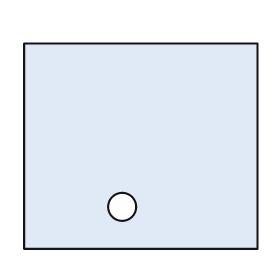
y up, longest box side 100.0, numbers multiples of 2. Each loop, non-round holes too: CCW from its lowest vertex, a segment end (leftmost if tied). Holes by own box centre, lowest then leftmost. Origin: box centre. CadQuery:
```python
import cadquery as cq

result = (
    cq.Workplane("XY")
    .moveTo(-50.0, -44.0)
    .lineTo(50.0, -44.0)
    .lineTo(50.0, 44.0)
    .lineTo(-50.0, 44.0)
    .close()
    .moveTo(-8.0, -26.0)
    .circle(6.0)
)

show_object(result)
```